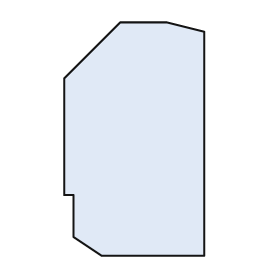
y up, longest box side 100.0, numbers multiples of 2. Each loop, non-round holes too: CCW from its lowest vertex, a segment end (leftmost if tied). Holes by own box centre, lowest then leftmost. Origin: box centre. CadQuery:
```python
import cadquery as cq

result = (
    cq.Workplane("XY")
    .moveTo(-14.0, -50.0)
    .lineTo(30.0, -50.0)
    .lineTo(30.0, 46.0)
    .lineTo(14.0, 50.0)
    .lineTo(-6.0, 50.0)
    .lineTo(-30.0, 26.0)
    .lineTo(-30.0, -24.0)
    .lineTo(-26.0, -24.0)
    .lineTo(-26.0, -42.0)
    .close()
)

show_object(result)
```